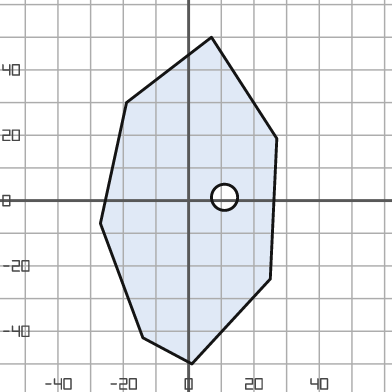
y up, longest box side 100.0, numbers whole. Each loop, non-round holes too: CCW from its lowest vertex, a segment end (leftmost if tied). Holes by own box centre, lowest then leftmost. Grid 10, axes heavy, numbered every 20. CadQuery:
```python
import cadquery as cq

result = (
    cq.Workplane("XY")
    .moveTo(1.0, -50.0)
    .lineTo(25.0, -24.0)
    .lineTo(27.0, 19.0)
    .lineTo(7.0, 50.0)
    .lineTo(-19.0, 30.0)
    .lineTo(-27.0, -7.0)
    .lineTo(-14.0, -42.0)
    .close()
    .moveTo(11.0, 1.0)
    .circle(4.0)
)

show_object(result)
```